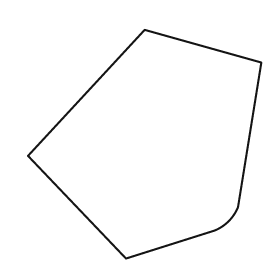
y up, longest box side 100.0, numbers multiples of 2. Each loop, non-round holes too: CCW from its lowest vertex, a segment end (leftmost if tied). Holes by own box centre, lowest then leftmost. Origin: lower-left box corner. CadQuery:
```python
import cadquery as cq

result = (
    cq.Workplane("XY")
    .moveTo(42.0, 0.0)
    .lineTo(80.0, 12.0)
    .threePointArc((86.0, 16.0), (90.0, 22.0))
    .lineTo(100.0, 84.0)
    .lineTo(50.0, 98.0)
    .lineTo(0.0, 44.0)
    .close()
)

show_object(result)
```